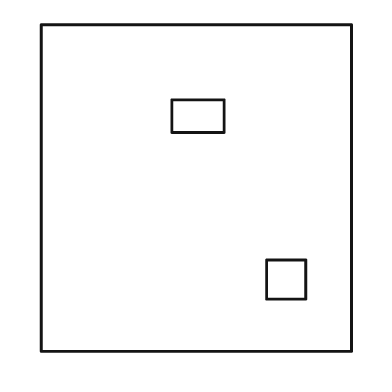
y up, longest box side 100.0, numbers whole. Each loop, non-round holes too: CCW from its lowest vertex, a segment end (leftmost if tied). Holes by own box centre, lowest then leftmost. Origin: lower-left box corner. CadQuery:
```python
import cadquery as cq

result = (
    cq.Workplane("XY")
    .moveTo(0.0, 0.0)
    .lineTo(95.0, 0.0)
    .lineTo(95.0, 100.0)
    .lineTo(0.0, 100.0)
    .close()
    .moveTo(69.0, 16.0)
    .lineTo(81.0, 16.0)
    .lineTo(81.0, 28.0)
    .lineTo(69.0, 28.0)
    .close()
    .moveTo(40.0, 67.0)
    .lineTo(56.0, 67.0)
    .lineTo(56.0, 77.0)
    .lineTo(40.0, 77.0)
    .close()
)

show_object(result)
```